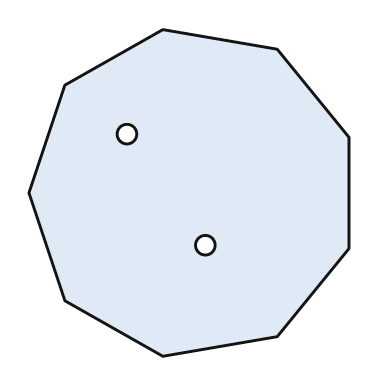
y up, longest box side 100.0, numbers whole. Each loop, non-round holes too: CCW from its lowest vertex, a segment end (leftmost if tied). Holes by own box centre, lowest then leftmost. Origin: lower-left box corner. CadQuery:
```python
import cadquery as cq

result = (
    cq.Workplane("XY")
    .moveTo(41.0, 0.0)
    .lineTo(76.0, 6.0)
    .lineTo(98.0, 33.0)
    .lineTo(98.0, 67.0)
    .lineTo(76.0, 94.0)
    .lineTo(41.0, 100.0)
    .lineTo(11.0, 83.0)
    .lineTo(0.0, 50.0)
    .lineTo(11.0, 17.0)
    .close()
    .moveTo(54.0, 34.0)
    .circle(3.0)
    .moveTo(30.0, 68.0)
    .circle(3.0)
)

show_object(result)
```